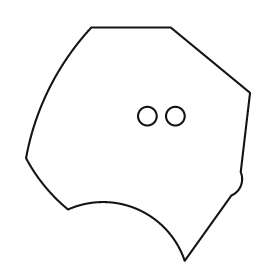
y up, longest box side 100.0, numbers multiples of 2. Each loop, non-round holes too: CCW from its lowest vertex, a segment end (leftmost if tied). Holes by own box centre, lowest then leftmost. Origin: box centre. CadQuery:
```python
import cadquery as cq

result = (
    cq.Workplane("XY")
    .moveTo(20.0, -50.0)
    .lineTo(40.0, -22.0)
    .threePointArc((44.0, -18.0), (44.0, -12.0))
    .lineTo(48.0, 22.0)
    .lineTo(14.0, 50.0)
    .lineTo(-20.0, 50.0)
    .threePointArc((-38.0, 24.0), (-48.0, -6.0))
    .threePointArc((-40.0, -18.0), (-30.0, -28.0))
    .threePointArc((0.0, -28.0), (20.0, -50.0))
    .close()
    .moveTo(4.0, 12.0)
    .circle(4.0)
    .moveTo(16.0, 12.0)
    .circle(4.0)
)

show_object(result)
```